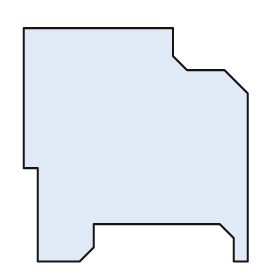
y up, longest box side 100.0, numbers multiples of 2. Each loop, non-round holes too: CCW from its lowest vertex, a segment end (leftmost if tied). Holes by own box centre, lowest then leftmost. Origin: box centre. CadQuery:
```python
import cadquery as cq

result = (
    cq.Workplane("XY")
    .moveTo(-42.0, -50.0)
    .lineTo(-24.0, -50.0)
    .lineTo(-18.0, -44.0)
    .lineTo(-18.0, -34.0)
    .lineTo(36.0, -34.0)
    .lineTo(42.0, -40.0)
    .lineTo(42.0, -50.0)
    .lineTo(48.0, -50.0)
    .lineTo(48.0, 22.0)
    .lineTo(38.0, 32.0)
    .lineTo(22.0, 32.0)
    .lineTo(16.0, 38.0)
    .lineTo(16.0, 50.0)
    .lineTo(-48.0, 50.0)
    .lineTo(-48.0, -10.0)
    .lineTo(-42.0, -10.0)
    .close()
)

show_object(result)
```